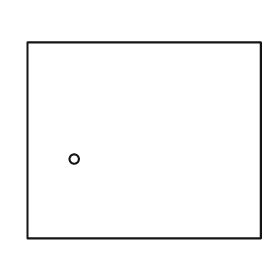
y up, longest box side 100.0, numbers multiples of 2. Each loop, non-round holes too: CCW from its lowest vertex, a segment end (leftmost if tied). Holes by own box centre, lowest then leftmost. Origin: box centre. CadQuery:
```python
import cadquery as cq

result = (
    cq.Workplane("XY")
    .moveTo(-50.0, -42.0)
    .lineTo(50.0, -42.0)
    .lineTo(50.0, 42.0)
    .lineTo(-50.0, 42.0)
    .close()
    .moveTo(-30.0, -8.0)
    .circle(2.0)
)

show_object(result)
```